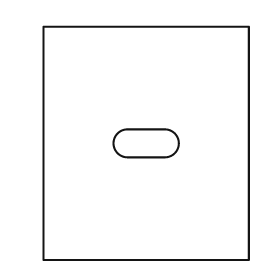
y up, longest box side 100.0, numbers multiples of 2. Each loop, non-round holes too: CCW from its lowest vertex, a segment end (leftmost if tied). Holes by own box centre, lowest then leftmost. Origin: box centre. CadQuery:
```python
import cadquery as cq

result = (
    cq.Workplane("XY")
    .moveTo(-44.0, -50.0)
    .lineTo(44.0, -50.0)
    .lineTo(44.0, 50.0)
    .lineTo(-44.0, 50.0)
    .close()
    .moveTo(-8.0, -6.0)
    .lineTo(8.0, -6.0)
    .threePointArc((14.0, 0.0), (8.0, 6.0))
    .lineTo(-8.0, 6.0)
    .threePointArc((-14.0, 0.0), (-8.0, -6.0))
    .close()
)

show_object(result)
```